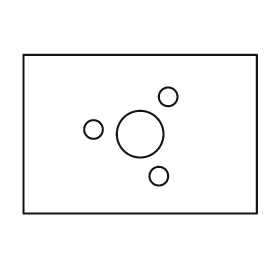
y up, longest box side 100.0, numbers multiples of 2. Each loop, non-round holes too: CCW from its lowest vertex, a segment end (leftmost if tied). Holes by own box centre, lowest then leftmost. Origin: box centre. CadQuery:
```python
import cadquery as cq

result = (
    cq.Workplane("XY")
    .moveTo(-50.0, -34.0)
    .lineTo(50.0, -34.0)
    .lineTo(50.0, 34.0)
    .lineTo(-50.0, 34.0)
    .close()
    .moveTo(8.0, -18.0)
    .circle(4.0)
    .moveTo(0.0, 0.0)
    .circle(10.0)
    .moveTo(-20.0, 2.0)
    .circle(4.0)
    .moveTo(12.0, 16.0)
    .circle(4.0)
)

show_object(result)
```